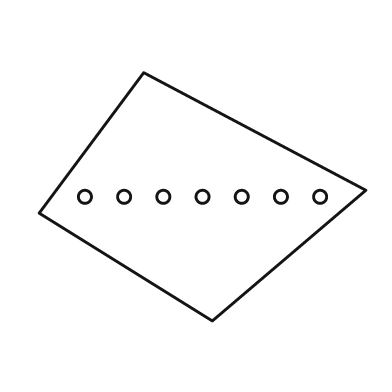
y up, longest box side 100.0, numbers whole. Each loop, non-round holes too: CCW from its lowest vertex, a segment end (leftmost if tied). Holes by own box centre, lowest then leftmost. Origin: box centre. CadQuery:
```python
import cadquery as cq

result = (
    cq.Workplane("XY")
    .moveTo(3.0, -38.0)
    .lineTo(50.0, 2.0)
    .lineTo(-18.0, 38.0)
    .lineTo(-50.0, -5.0)
    .close()
    .moveTo(-36.0, 0.0)
    .circle(2.0)
    .moveTo(-24.0, 0.0)
    .circle(2.0)
    .moveTo(-12.0, 0.0)
    .circle(2.0)
    .moveTo(0.0, 0.0)
    .circle(2.0)
    .moveTo(12.0, 0.0)
    .circle(2.0)
    .moveTo(24.0, 0.0)
    .circle(2.0)
    .moveTo(36.0, 0.0)
    .circle(2.0)
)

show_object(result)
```